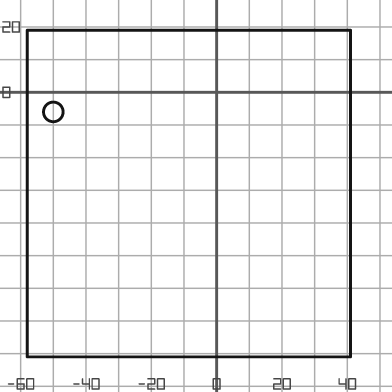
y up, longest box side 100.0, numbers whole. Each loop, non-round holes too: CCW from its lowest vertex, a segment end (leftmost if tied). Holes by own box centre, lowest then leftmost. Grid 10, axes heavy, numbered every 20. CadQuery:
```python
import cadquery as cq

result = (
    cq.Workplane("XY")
    .moveTo(-58.0, -81.0)
    .lineTo(41.0, -81.0)
    .lineTo(41.0, 19.0)
    .lineTo(-58.0, 19.0)
    .close()
    .moveTo(-50.0, -6.0)
    .circle(3.0)
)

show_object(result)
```